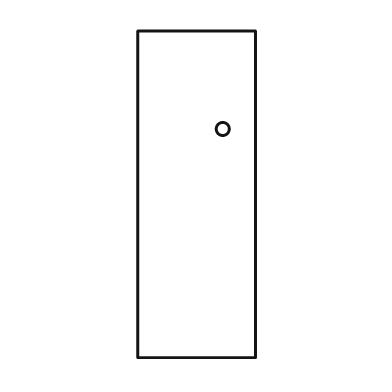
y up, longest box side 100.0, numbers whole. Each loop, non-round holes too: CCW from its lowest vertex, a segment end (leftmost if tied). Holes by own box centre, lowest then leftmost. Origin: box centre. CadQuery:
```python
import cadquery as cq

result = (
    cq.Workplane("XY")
    .moveTo(-18.0, -50.0)
    .lineTo(18.0, -50.0)
    .lineTo(18.0, 50.0)
    .lineTo(-18.0, 50.0)
    .close()
    .moveTo(8.0, 20.0)
    .circle(2.0)
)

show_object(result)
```